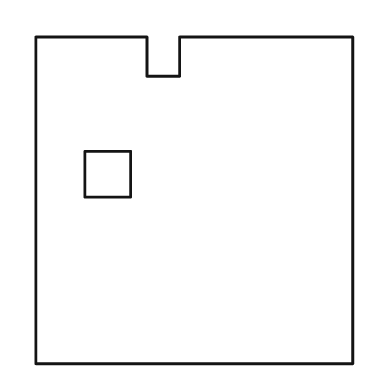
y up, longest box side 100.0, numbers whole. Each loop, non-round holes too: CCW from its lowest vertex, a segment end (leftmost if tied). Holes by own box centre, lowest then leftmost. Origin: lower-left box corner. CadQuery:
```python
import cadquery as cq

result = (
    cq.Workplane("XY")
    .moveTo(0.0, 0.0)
    .lineTo(97.0, 0.0)
    .lineTo(97.0, 100.0)
    .lineTo(44.0, 100.0)
    .lineTo(44.0, 88.0)
    .lineTo(34.0, 88.0)
    .lineTo(34.0, 100.0)
    .lineTo(0.0, 100.0)
    .close()
    .moveTo(15.0, 51.0)
    .lineTo(29.0, 51.0)
    .lineTo(29.0, 65.0)
    .lineTo(15.0, 65.0)
    .close()
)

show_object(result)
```